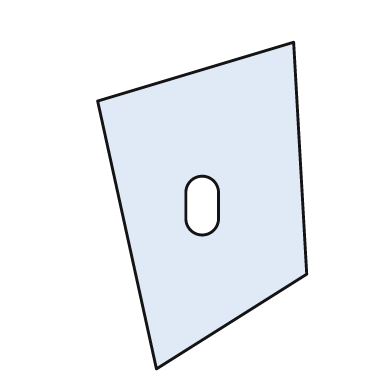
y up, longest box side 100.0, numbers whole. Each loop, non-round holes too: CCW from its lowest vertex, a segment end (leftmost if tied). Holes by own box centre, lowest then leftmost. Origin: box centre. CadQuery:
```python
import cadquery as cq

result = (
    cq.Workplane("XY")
    .moveTo(-14.0, -50.0)
    .lineTo(32.0, -21.0)
    .lineTo(28.0, 50.0)
    .lineTo(-32.0, 32.0)
    .close()
    .moveTo(-5.0, -4.0)
    .threePointArc((0.0, -9.0), (5.0, -4.0))
    .lineTo(5.0, 4.0)
    .threePointArc((0.0, 9.0), (-5.0, 4.0))
    .close()
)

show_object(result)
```